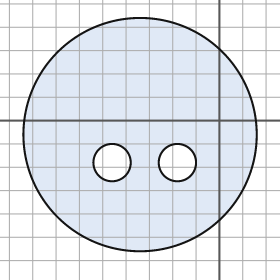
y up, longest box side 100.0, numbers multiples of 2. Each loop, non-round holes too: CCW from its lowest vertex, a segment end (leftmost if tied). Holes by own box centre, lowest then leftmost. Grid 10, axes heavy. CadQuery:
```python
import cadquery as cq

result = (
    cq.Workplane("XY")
    .moveTo(-34.0, -6.0)
    .circle(50.0)
    .moveTo(-46.0, -18.0)
    .circle(8.0)
    .moveTo(-18.0, -18.0)
    .circle(8.0)
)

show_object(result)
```